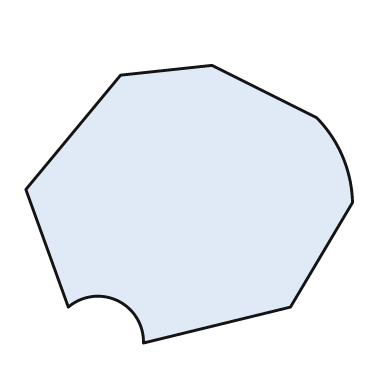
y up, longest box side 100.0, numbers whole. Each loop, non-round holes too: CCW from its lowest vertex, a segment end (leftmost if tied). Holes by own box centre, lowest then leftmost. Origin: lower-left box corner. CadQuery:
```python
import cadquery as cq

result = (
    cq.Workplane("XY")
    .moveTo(36.0, 0.0)
    .lineTo(81.0, 11.0)
    .lineTo(100.0, 43.0)
    .threePointArc((97.0, 57.0), (89.0, 69.0))
    .lineTo(57.0, 85.0)
    .lineTo(29.0, 82.0)
    .lineTo(0.0, 47.0)
    .lineTo(13.0, 11.0)
    .threePointArc((28.0, 13.0), (36.0, 0.0))
    .close()
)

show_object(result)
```